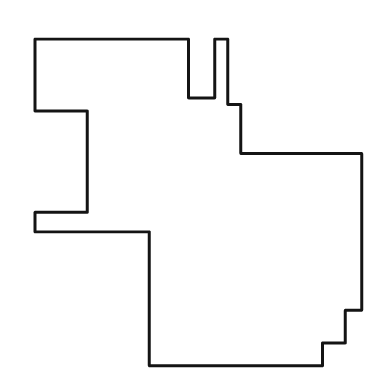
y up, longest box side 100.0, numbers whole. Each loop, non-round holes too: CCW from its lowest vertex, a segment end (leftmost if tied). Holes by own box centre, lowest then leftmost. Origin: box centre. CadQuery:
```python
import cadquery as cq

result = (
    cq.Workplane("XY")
    .moveTo(-15.0, -50.0)
    .lineTo(38.0, -50.0)
    .lineTo(38.0, -43.0)
    .lineTo(45.0, -43.0)
    .lineTo(45.0, -33.0)
    .lineTo(50.0, -33.0)
    .lineTo(50.0, 15.0)
    .lineTo(13.0, 15.0)
    .lineTo(13.0, 30.0)
    .lineTo(9.0, 30.0)
    .lineTo(9.0, 50.0)
    .lineTo(5.0, 50.0)
    .lineTo(5.0, 32.0)
    .lineTo(-3.0, 32.0)
    .lineTo(-3.0, 50.0)
    .lineTo(-50.0, 50.0)
    .lineTo(-50.0, 28.0)
    .lineTo(-34.0, 28.0)
    .lineTo(-34.0, -3.0)
    .lineTo(-50.0, -3.0)
    .lineTo(-50.0, -9.0)
    .lineTo(-15.0, -9.0)
    .close()
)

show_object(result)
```